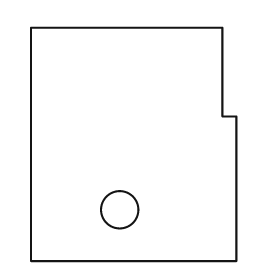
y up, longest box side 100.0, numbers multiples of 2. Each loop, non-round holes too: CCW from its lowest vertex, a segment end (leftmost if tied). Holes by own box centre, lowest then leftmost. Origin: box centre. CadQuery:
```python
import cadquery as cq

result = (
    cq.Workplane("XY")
    .moveTo(-44.0, -50.0)
    .lineTo(44.0, -50.0)
    .lineTo(44.0, 12.0)
    .lineTo(38.0, 12.0)
    .lineTo(38.0, 50.0)
    .lineTo(-44.0, 50.0)
    .close()
    .moveTo(-6.0, -28.0)
    .circle(8.0)
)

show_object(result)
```